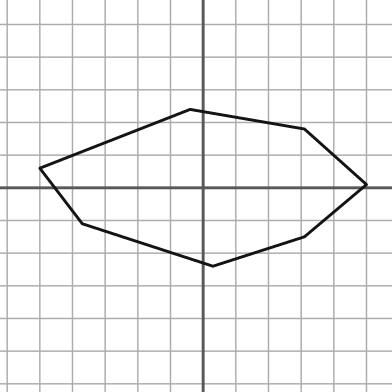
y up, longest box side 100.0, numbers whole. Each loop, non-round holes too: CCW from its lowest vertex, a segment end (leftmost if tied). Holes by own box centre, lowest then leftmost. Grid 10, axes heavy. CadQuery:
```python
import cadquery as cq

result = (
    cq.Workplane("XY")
    .moveTo(3.0, -24.0)
    .lineTo(31.0, -15.0)
    .lineTo(50.0, 1.0)
    .lineTo(31.0, 18.0)
    .lineTo(-4.0, 24.0)
    .lineTo(-50.0, 6.0)
    .lineTo(-37.0, -11.0)
    .close()
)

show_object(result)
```